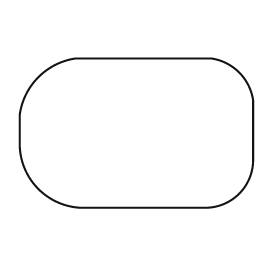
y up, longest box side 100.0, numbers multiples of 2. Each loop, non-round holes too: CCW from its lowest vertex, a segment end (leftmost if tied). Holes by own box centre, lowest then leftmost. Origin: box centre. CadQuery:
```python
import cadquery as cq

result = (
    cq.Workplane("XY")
    .moveTo(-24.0, -32.0)
    .lineTo(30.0, -32.0)
    .threePointArc((44.0, -26.0), (50.0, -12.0))
    .lineTo(50.0, 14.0)
    .threePointArc((44.0, 26.0), (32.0, 32.0))
    .lineTo(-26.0, 32.0)
    .threePointArc((-42.0, 24.0), (-50.0, 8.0))
    .lineTo(-50.0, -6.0)
    .threePointArc((-42.0, -24.0), (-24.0, -32.0))
    .close()
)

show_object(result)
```